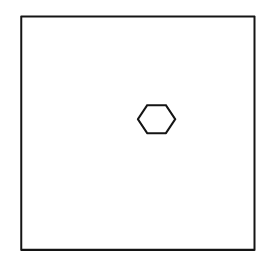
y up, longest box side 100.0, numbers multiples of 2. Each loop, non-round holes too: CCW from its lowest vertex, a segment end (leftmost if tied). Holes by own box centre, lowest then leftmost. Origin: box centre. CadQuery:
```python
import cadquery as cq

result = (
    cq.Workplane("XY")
    .moveTo(-50.0, -50.0)
    .lineTo(50.0, -50.0)
    .lineTo(50.0, 50.0)
    .lineTo(-50.0, 50.0)
    .close()
    .moveTo(4.0, 0.0)
    .lineTo(12.0, 0.0)
    .lineTo(16.0, 6.0)
    .lineTo(12.0, 12.0)
    .lineTo(4.0, 12.0)
    .lineTo(0.0, 6.0)
    .close()
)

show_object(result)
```